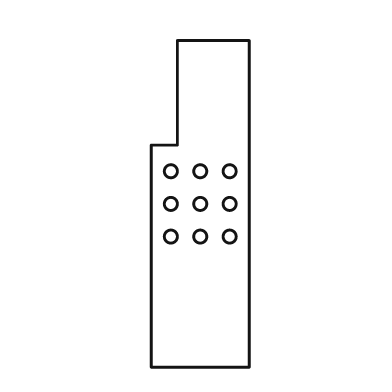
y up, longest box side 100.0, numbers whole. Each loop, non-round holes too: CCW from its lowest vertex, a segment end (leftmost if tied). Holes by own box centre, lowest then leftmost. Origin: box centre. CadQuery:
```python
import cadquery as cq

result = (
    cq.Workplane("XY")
    .moveTo(-15.0, -50.0)
    .lineTo(15.0, -50.0)
    .lineTo(15.0, 50.0)
    .lineTo(-7.0, 50.0)
    .lineTo(-7.0, 18.0)
    .lineTo(-15.0, 18.0)
    .close()
    .moveTo(-9.0, -10.0)
    .circle(2.0)
    .moveTo(0.0, -10.0)
    .circle(2.0)
    .moveTo(9.0, -10.0)
    .circle(2.0)
    .moveTo(-9.0, 0.0)
    .circle(2.0)
    .moveTo(0.0, 0.0)
    .circle(2.0)
    .moveTo(9.0, 0.0)
    .circle(2.0)
    .moveTo(-9.0, 10.0)
    .circle(2.0)
    .moveTo(0.0, 10.0)
    .circle(2.0)
    .moveTo(9.0, 10.0)
    .circle(2.0)
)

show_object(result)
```